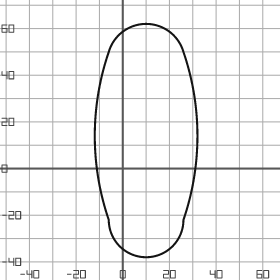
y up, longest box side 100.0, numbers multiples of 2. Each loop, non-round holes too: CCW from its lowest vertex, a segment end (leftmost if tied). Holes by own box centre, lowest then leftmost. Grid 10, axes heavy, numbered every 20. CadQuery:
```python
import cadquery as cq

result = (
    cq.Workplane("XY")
    .moveTo(-6.0, -22.0)
    .threePointArc((10.0, -38.0), (26.0, -22.0))
    .threePointArc((32.0, 14.0), (26.0, 50.0))
    .threePointArc((10.0, 62.0), (-6.0, 50.0))
    .threePointArc((-12.0, 14.0), (-6.0, -22.0))
    .close()
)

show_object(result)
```